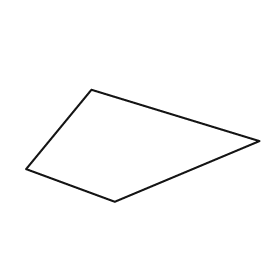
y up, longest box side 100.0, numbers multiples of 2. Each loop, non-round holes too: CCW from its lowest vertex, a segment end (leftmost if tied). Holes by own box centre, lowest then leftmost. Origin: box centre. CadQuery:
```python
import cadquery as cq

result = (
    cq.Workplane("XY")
    .moveTo(-12.0, -24.0)
    .lineTo(50.0, 2.0)
    .lineTo(-22.0, 24.0)
    .lineTo(-50.0, -10.0)
    .close()
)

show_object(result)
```